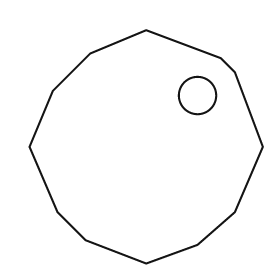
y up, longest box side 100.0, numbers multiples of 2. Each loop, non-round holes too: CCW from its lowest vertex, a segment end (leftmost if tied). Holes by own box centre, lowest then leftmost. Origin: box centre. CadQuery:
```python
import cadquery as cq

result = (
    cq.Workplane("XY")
    .moveTo(0.0, -50.0)
    .lineTo(22.0, -42.0)
    .lineTo(38.0, -28.0)
    .lineTo(50.0, 0.0)
    .lineTo(38.0, 32.0)
    .lineTo(32.0, 38.0)
    .lineTo(0.0, 50.0)
    .lineTo(-24.0, 40.0)
    .lineTo(-40.0, 24.0)
    .lineTo(-50.0, 0.0)
    .lineTo(-38.0, -28.0)
    .lineTo(-26.0, -40.0)
    .close()
    .moveTo(22.0, 22.0)
    .circle(8.0)
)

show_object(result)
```